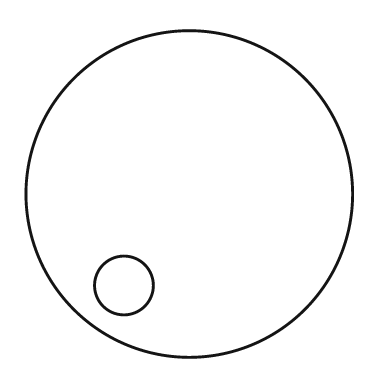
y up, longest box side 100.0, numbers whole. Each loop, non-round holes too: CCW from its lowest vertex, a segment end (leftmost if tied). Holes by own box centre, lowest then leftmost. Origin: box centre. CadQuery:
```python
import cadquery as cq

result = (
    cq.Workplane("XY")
    .moveTo(0.0, 0.0)
    .circle(50.0)
    .moveTo(-20.0, -28.0)
    .circle(9.0)
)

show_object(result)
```